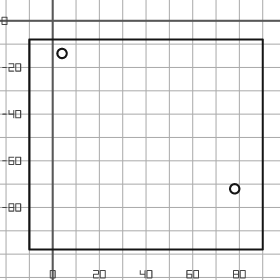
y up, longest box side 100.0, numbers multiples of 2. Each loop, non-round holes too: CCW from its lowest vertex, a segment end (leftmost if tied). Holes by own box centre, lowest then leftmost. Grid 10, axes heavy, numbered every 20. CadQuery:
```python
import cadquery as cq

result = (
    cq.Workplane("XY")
    .moveTo(-10.0, -98.0)
    .lineTo(90.0, -98.0)
    .lineTo(90.0, -8.0)
    .lineTo(-10.0, -8.0)
    .close()
    .moveTo(78.0, -72.0)
    .circle(2.0)
    .moveTo(4.0, -14.0)
    .circle(2.0)
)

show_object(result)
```